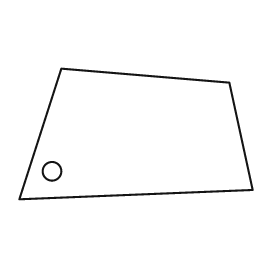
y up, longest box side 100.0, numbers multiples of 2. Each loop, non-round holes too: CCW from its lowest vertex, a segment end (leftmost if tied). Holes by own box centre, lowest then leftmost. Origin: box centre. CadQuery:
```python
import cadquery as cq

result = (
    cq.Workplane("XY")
    .moveTo(-50.0, -28.0)
    .lineTo(50.0, -24.0)
    .lineTo(40.0, 22.0)
    .lineTo(-32.0, 28.0)
    .close()
    .moveTo(-36.0, -16.0)
    .circle(4.0)
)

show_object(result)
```